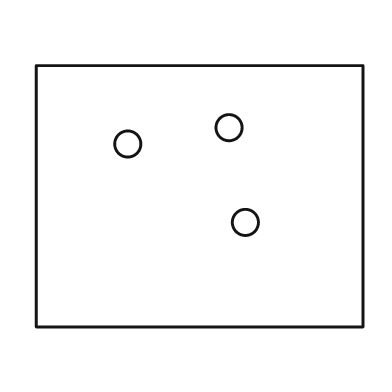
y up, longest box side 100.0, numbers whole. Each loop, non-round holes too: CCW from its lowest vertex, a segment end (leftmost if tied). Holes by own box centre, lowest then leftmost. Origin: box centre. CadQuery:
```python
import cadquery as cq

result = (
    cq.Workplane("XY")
    .moveTo(-50.0, -40.0)
    .lineTo(50.0, -40.0)
    .lineTo(50.0, 40.0)
    .lineTo(-50.0, 40.0)
    .close()
    .moveTo(14.0, -8.0)
    .circle(4.0)
    .moveTo(-22.0, 16.0)
    .circle(4.0)
    .moveTo(9.0, 21.0)
    .circle(4.0)
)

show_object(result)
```